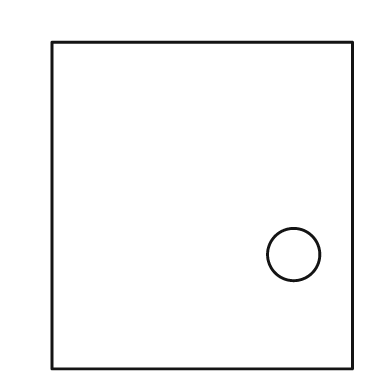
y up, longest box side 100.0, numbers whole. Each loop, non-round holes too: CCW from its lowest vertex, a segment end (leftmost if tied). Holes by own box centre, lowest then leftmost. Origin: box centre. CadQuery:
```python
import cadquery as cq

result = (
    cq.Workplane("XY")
    .moveTo(-46.0, -50.0)
    .lineTo(46.0, -50.0)
    .lineTo(46.0, 50.0)
    .lineTo(-46.0, 50.0)
    .close()
    .moveTo(28.0, -15.0)
    .circle(8.0)
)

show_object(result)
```